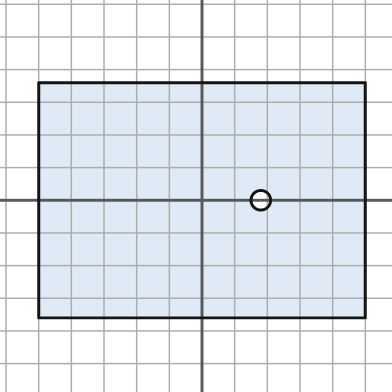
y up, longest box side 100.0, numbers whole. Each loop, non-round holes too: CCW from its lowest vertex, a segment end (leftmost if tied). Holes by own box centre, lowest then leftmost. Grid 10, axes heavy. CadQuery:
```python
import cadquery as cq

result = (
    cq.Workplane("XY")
    .moveTo(-50.0, -36.0)
    .lineTo(50.0, -36.0)
    .lineTo(50.0, 36.0)
    .lineTo(-50.0, 36.0)
    .close()
    .moveTo(18.0, 0.0)
    .circle(3.0)
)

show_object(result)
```